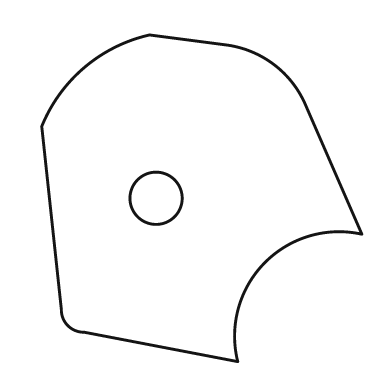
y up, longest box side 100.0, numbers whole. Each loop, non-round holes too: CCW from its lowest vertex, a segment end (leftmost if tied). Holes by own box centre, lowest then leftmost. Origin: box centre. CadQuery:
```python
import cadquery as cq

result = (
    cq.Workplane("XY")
    .moveTo(11.0, -50.0)
    .threePointArc((19.0, -20.0), (49.0, -11.0))
    .lineTo(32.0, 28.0)
    .threePointArc((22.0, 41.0), (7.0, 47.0))
    .lineTo(-16.0, 50.0)
    .threePointArc((-36.0, 40.0), (-49.0, 22.0))
    .lineTo(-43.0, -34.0)
    .threePointArc((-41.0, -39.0), (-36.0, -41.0))
    .close()
    .moveTo(-14.0, 0.0)
    .circle(8.0)
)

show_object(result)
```